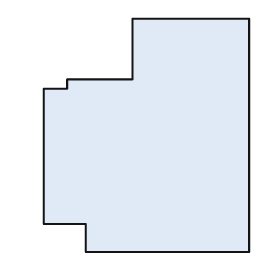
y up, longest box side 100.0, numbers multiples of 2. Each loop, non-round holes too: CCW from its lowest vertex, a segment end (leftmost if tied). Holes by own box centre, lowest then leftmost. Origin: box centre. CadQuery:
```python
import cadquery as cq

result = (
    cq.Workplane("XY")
    .moveTo(-26.0, -50.0)
    .lineTo(44.0, -50.0)
    .lineTo(44.0, 50.0)
    .lineTo(-6.0, 50.0)
    .lineTo(-6.0, 24.0)
    .lineTo(-34.0, 24.0)
    .lineTo(-34.0, 20.0)
    .lineTo(-44.0, 20.0)
    .lineTo(-44.0, -38.0)
    .lineTo(-26.0, -38.0)
    .close()
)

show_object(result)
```